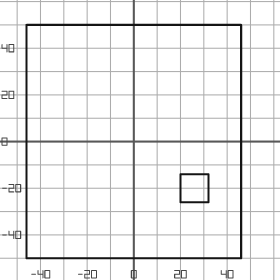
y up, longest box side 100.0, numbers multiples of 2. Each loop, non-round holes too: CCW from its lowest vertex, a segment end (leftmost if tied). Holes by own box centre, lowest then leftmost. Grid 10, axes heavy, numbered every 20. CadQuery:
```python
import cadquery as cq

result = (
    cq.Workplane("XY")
    .moveTo(-46.0, -50.0)
    .lineTo(46.0, -50.0)
    .lineTo(46.0, 50.0)
    .lineTo(-46.0, 50.0)
    .close()
    .moveTo(20.0, -26.0)
    .lineTo(32.0, -26.0)
    .lineTo(32.0, -14.0)
    .lineTo(20.0, -14.0)
    .close()
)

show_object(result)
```